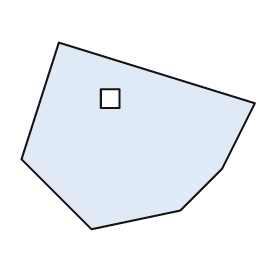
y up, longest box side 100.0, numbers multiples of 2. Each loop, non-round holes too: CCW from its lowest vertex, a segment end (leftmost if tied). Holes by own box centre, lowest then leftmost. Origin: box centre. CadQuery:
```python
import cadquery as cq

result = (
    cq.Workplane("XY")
    .moveTo(-20.0, -40.0)
    .lineTo(18.0, -32.0)
    .lineTo(36.0, -14.0)
    .lineTo(50.0, 14.0)
    .lineTo(-34.0, 40.0)
    .lineTo(-50.0, -10.0)
    .close()
    .moveTo(-16.0, 12.0)
    .lineTo(-8.0, 12.0)
    .lineTo(-8.0, 20.0)
    .lineTo(-16.0, 20.0)
    .close()
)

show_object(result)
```